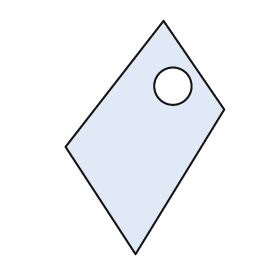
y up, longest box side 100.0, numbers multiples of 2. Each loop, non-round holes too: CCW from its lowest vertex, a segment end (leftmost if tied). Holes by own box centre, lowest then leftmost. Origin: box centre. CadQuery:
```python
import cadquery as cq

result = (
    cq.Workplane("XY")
    .moveTo(-4.0, -50.0)
    .lineTo(34.0, 12.0)
    .lineTo(8.0, 50.0)
    .lineTo(-34.0, -4.0)
    .close()
    .moveTo(12.0, 22.0)
    .circle(8.0)
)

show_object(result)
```